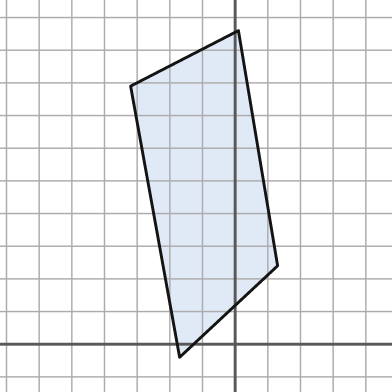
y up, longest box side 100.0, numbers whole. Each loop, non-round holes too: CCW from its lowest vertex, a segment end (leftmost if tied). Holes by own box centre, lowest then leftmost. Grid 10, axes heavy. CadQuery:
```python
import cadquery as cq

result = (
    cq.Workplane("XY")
    .moveTo(-17.0, -4.0)
    .lineTo(13.0, 24.0)
    .lineTo(1.0, 96.0)
    .lineTo(-32.0, 79.0)
    .close()
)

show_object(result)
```